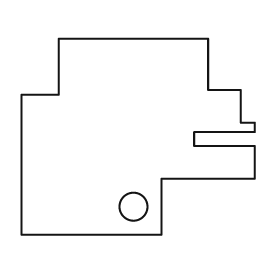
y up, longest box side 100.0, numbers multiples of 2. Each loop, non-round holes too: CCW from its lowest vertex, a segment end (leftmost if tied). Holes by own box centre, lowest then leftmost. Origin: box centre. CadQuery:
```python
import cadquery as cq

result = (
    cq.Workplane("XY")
    .moveTo(-50.0, -42.0)
    .lineTo(10.0, -42.0)
    .lineTo(10.0, -18.0)
    .lineTo(50.0, -18.0)
    .lineTo(50.0, -4.0)
    .lineTo(24.0, -4.0)
    .lineTo(24.0, 2.0)
    .lineTo(50.0, 2.0)
    .lineTo(50.0, 6.0)
    .lineTo(44.0, 6.0)
    .lineTo(44.0, 20.0)
    .lineTo(30.0, 20.0)
    .lineTo(30.0, 42.0)
    .lineTo(-34.0, 42.0)
    .lineTo(-34.0, 18.0)
    .lineTo(-50.0, 18.0)
    .close()
    .moveTo(-2.0, -30.0)
    .circle(6.0)
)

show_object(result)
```